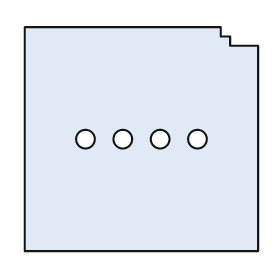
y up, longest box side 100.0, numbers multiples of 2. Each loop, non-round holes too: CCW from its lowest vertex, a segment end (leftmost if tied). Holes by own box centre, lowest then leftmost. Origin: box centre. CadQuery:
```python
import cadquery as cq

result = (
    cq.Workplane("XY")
    .moveTo(-50.0, -48.0)
    .lineTo(50.0, -48.0)
    .lineTo(50.0, 40.0)
    .lineTo(38.0, 40.0)
    .lineTo(38.0, 44.0)
    .lineTo(34.0, 44.0)
    .lineTo(34.0, 48.0)
    .lineTo(-50.0, 48.0)
    .close()
    .moveTo(-24.0, 0.0)
    .circle(4.0)
    .moveTo(-8.0, 0.0)
    .circle(4.0)
    .moveTo(8.0, 0.0)
    .circle(4.0)
    .moveTo(24.0, 0.0)
    .circle(4.0)
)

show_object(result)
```